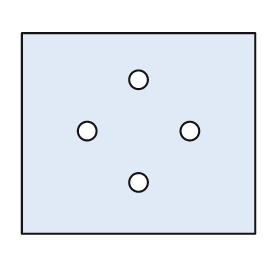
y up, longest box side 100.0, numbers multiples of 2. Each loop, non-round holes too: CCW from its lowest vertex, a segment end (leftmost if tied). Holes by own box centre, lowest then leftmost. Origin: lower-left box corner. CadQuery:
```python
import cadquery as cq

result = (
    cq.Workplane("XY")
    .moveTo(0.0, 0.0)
    .lineTo(100.0, 0.0)
    .lineTo(100.0, 86.0)
    .lineTo(0.0, 86.0)
    .close()
    .moveTo(50.0, 22.0)
    .circle(4.0)
    .moveTo(28.0, 44.0)
    .circle(4.0)
    .moveTo(72.0, 44.0)
    .circle(4.0)
    .moveTo(50.0, 66.0)
    .circle(4.0)
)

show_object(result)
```